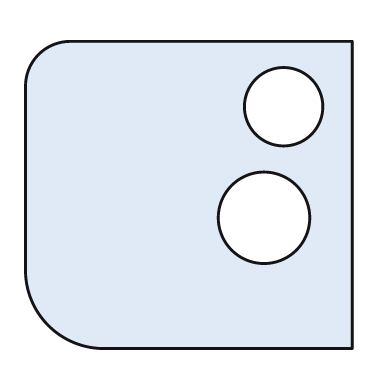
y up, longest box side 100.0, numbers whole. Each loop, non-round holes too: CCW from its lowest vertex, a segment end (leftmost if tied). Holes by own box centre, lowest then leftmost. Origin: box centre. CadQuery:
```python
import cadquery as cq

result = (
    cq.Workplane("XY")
    .moveTo(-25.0, -47.0)
    .lineTo(50.0, -47.0)
    .lineTo(50.0, 47.0)
    .lineTo(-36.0, 47.0)
    .threePointArc((-46.0, 43.0), (-50.0, 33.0))
    .lineTo(-50.0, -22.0)
    .threePointArc((-43.0, -40.0), (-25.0, -47.0))
    .close()
    .moveTo(23.0, -7.0)
    .circle(14.0)
    .moveTo(29.0, 27.0)
    .circle(12.0)
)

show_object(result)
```